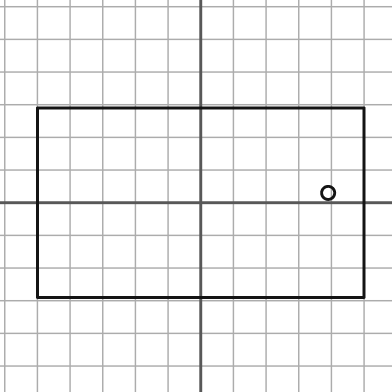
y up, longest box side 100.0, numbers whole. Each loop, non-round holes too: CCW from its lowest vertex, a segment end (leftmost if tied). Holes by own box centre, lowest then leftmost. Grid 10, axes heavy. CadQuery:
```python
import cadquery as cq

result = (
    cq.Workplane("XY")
    .moveTo(-50.0, -29.0)
    .lineTo(50.0, -29.0)
    .lineTo(50.0, 29.0)
    .lineTo(-50.0, 29.0)
    .close()
    .moveTo(39.0, 3.0)
    .circle(2.0)
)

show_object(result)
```